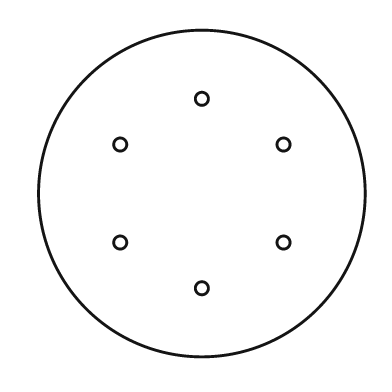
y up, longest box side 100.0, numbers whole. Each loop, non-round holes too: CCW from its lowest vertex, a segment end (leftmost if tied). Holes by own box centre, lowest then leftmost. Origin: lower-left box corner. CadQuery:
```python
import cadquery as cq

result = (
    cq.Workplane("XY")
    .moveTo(50.0, 50.0)
    .circle(50.0)
    .moveTo(50.0, 21.0)
    .circle(2.0)
    .moveTo(25.0, 35.0)
    .circle(2.0)
    .moveTo(75.0, 35.0)
    .circle(2.0)
    .moveTo(25.0, 65.0)
    .circle(2.0)
    .moveTo(75.0, 65.0)
    .circle(2.0)
    .moveTo(50.0, 79.0)
    .circle(2.0)
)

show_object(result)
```